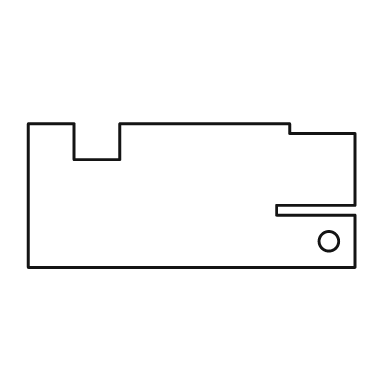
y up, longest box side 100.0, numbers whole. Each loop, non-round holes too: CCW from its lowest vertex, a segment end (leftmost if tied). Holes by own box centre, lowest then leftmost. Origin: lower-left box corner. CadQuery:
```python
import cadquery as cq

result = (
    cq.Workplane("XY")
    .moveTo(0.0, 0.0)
    .lineTo(100.0, 0.0)
    .lineTo(100.0, 16.0)
    .lineTo(76.0, 16.0)
    .lineTo(76.0, 19.0)
    .lineTo(100.0, 19.0)
    .lineTo(100.0, 41.0)
    .lineTo(80.0, 41.0)
    .lineTo(80.0, 44.0)
    .lineTo(28.0, 44.0)
    .lineTo(28.0, 33.0)
    .lineTo(14.0, 33.0)
    .lineTo(14.0, 44.0)
    .lineTo(0.0, 44.0)
    .close()
    .moveTo(92.0, 8.0)
    .circle(3.0)
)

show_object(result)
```